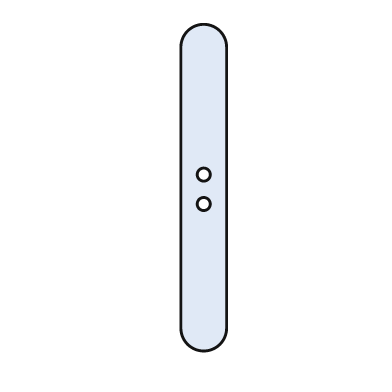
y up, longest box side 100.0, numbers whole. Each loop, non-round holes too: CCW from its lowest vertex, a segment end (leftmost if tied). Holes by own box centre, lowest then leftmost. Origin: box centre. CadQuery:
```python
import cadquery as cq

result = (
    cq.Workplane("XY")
    .moveTo(-7.0, -43.0)
    .threePointArc((0.0, -50.0), (7.0, -43.0))
    .lineTo(7.0, 43.0)
    .threePointArc((0.0, 50.0), (-7.0, 43.0))
    .close()
    .moveTo(0.0, -5.0)
    .circle(2.0)
    .moveTo(0.0, 4.0)
    .circle(2.0)
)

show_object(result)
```